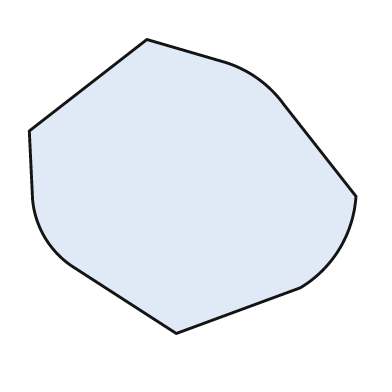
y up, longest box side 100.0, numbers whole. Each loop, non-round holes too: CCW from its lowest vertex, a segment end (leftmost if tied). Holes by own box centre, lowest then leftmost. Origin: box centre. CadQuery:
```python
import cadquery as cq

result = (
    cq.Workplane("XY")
    .moveTo(-5.0, -45.0)
    .lineTo(33.0, -31.0)
    .threePointArc((45.0, -19.0), (50.0, -3.0))
    .lineTo(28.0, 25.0)
    .threePointArc((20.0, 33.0), (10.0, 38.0))
    .lineTo(-14.0, 45.0)
    .lineTo(-50.0, 17.0)
    .lineTo(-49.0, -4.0)
    .threePointArc((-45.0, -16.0), (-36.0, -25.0))
    .close()
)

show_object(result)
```